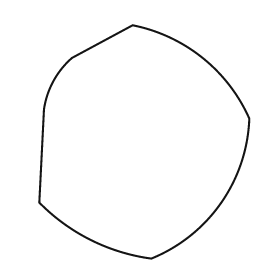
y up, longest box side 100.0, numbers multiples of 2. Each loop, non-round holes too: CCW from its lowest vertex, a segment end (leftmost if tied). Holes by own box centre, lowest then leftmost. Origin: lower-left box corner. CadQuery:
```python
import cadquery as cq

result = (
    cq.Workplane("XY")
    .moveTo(48.0, 0.0)
    .threePointArc((78.0, 24.0), (90.0, 60.0))
    .threePointArc((70.0, 86.0), (40.0, 100.0))
    .lineTo(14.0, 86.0)
    .threePointArc((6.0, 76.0), (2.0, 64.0))
    .lineTo(0.0, 24.0)
    .threePointArc((22.0, 8.0), (48.0, 0.0))
    .close()
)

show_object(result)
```